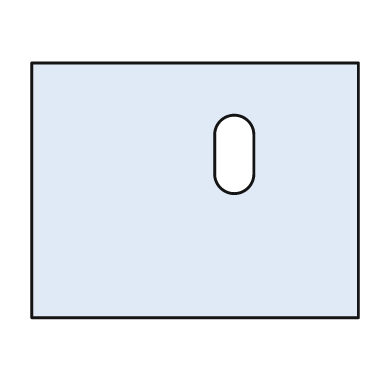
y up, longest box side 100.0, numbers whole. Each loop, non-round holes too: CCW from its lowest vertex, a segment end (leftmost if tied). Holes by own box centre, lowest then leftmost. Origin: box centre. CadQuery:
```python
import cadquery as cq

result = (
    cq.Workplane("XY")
    .moveTo(-50.0, -39.0)
    .lineTo(50.0, -39.0)
    .lineTo(50.0, 39.0)
    .lineTo(-50.0, 39.0)
    .close()
    .moveTo(6.0, 5.0)
    .threePointArc((12.0, -1.0), (18.0, 5.0))
    .lineTo(18.0, 17.0)
    .threePointArc((12.0, 23.0), (6.0, 17.0))
    .close()
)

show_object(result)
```